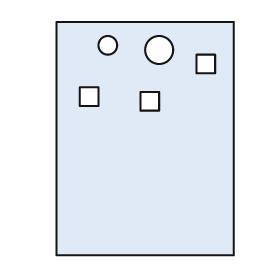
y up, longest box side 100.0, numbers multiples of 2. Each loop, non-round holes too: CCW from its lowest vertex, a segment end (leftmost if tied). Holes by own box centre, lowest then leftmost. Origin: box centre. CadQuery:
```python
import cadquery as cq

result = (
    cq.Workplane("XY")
    .moveTo(-38.0, -50.0)
    .lineTo(38.0, -50.0)
    .lineTo(38.0, 50.0)
    .lineTo(-38.0, 50.0)
    .close()
    .moveTo(-2.0, 12.0)
    .lineTo(6.0, 12.0)
    .lineTo(6.0, 20.0)
    .lineTo(-2.0, 20.0)
    .close()
    .moveTo(-28.0, 14.0)
    .lineTo(-20.0, 14.0)
    .lineTo(-20.0, 22.0)
    .lineTo(-28.0, 22.0)
    .close()
    .moveTo(22.0, 28.0)
    .lineTo(30.0, 28.0)
    .lineTo(30.0, 36.0)
    .lineTo(22.0, 36.0)
    .close()
    .moveTo(6.0, 38.0)
    .circle(6.0)
    .moveTo(-16.0, 40.0)
    .circle(4.0)
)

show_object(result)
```